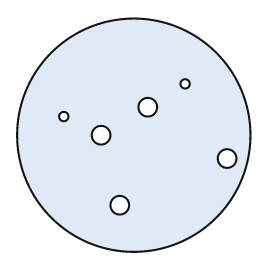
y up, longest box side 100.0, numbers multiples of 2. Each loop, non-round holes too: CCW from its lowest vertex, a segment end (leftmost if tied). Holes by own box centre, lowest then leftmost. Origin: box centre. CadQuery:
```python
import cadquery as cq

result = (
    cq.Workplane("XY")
    .moveTo(0.0, 0.0)
    .circle(50.0)
    .moveTo(-6.0, -30.0)
    .circle(4.0)
    .moveTo(40.0, -10.0)
    .circle(4.0)
    .moveTo(-14.0, 0.0)
    .circle(4.0)
    .moveTo(-30.0, 8.0)
    .circle(2.0)
    .moveTo(6.0, 12.0)
    .circle(4.0)
    .moveTo(22.0, 22.0)
    .circle(2.0)
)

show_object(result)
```